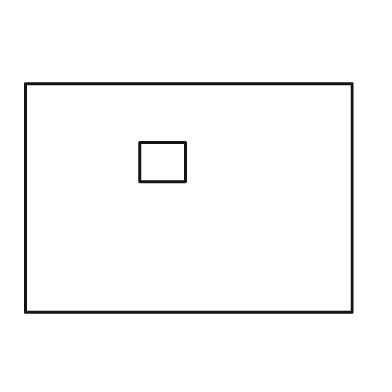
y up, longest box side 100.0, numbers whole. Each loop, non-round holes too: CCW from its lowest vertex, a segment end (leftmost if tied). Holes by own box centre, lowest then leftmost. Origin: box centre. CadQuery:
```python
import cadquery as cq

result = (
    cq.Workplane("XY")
    .moveTo(-50.0, -35.0)
    .lineTo(50.0, -35.0)
    .lineTo(50.0, 35.0)
    .lineTo(-50.0, 35.0)
    .close()
    .moveTo(-15.0, 5.0)
    .lineTo(-1.0, 5.0)
    .lineTo(-1.0, 17.0)
    .lineTo(-15.0, 17.0)
    .close()
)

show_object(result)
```